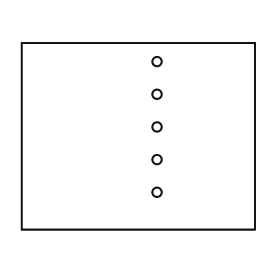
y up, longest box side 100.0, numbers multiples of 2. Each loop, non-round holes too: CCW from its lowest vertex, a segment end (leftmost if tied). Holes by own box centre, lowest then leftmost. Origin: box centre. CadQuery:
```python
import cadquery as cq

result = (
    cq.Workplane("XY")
    .moveTo(-50.0, -40.0)
    .lineTo(50.0, -40.0)
    .lineTo(50.0, 40.0)
    .lineTo(-50.0, 40.0)
    .close()
    .moveTo(8.0, -24.0)
    .circle(2.0)
    .moveTo(8.0, -10.0)
    .circle(2.0)
    .moveTo(8.0, 4.0)
    .circle(2.0)
    .moveTo(8.0, 18.0)
    .circle(2.0)
    .moveTo(8.0, 32.0)
    .circle(2.0)
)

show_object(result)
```